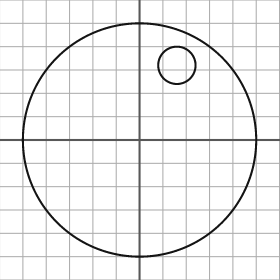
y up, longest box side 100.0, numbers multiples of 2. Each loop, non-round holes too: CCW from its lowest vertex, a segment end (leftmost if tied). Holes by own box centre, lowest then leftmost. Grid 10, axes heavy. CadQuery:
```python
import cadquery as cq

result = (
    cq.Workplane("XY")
    .moveTo(0.0, 0.0)
    .circle(50.0)
    .moveTo(16.0, 32.0)
    .circle(8.0)
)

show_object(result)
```